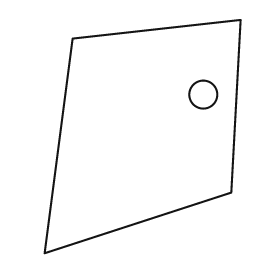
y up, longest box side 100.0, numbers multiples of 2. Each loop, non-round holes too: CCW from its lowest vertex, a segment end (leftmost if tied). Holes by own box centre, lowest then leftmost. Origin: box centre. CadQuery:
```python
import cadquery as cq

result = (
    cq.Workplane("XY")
    .moveTo(-42.0, -50.0)
    .lineTo(38.0, -24.0)
    .lineTo(42.0, 50.0)
    .lineTo(-30.0, 42.0)
    .close()
    .moveTo(26.0, 18.0)
    .circle(6.0)
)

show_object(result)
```